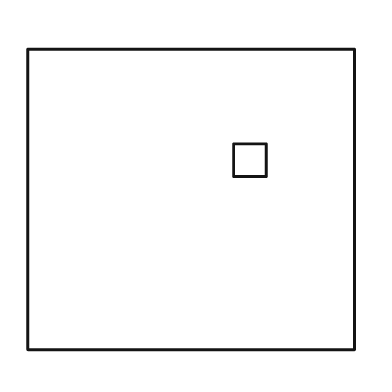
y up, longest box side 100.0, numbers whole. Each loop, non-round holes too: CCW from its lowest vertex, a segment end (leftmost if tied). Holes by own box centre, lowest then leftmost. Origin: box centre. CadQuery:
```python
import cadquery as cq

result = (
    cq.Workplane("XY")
    .moveTo(-50.0, -46.0)
    .lineTo(50.0, -46.0)
    .lineTo(50.0, 46.0)
    .lineTo(-50.0, 46.0)
    .close()
    .moveTo(13.0, 7.0)
    .lineTo(23.0, 7.0)
    .lineTo(23.0, 17.0)
    .lineTo(13.0, 17.0)
    .close()
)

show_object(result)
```